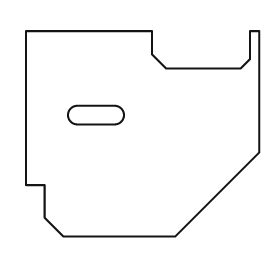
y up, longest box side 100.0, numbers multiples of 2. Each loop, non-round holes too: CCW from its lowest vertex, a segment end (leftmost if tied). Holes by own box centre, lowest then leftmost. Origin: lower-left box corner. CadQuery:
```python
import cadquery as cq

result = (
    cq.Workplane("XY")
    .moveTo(16.0, 0.0)
    .lineTo(64.0, 0.0)
    .lineTo(100.0, 36.0)
    .lineTo(100.0, 88.0)
    .lineTo(96.0, 88.0)
    .lineTo(96.0, 76.0)
    .lineTo(92.0, 72.0)
    .lineTo(60.0, 72.0)
    .lineTo(54.0, 78.0)
    .lineTo(54.0, 88.0)
    .lineTo(0.0, 88.0)
    .lineTo(0.0, 22.0)
    .lineTo(8.0, 22.0)
    .lineTo(8.0, 8.0)
    .close()
    .moveTo(22.0, 48.0)
    .lineTo(38.0, 48.0)
    .threePointArc((42.0, 52.0), (38.0, 56.0))
    .lineTo(22.0, 56.0)
    .threePointArc((18.0, 52.0), (22.0, 48.0))
    .close()
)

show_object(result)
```